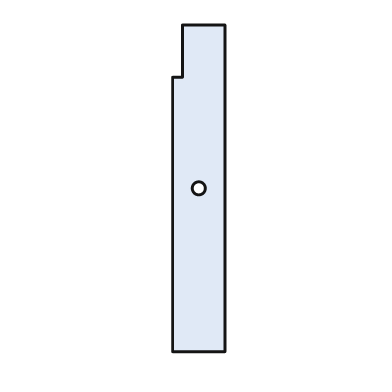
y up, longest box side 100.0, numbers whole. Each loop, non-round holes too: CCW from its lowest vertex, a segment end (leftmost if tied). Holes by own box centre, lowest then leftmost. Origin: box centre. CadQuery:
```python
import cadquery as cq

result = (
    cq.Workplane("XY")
    .moveTo(-8.0, -50.0)
    .lineTo(8.0, -50.0)
    .lineTo(8.0, 50.0)
    .lineTo(-5.0, 50.0)
    .lineTo(-5.0, 34.0)
    .lineTo(-8.0, 34.0)
    .close()
    .moveTo(0.0, 0.0)
    .circle(2.0)
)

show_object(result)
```